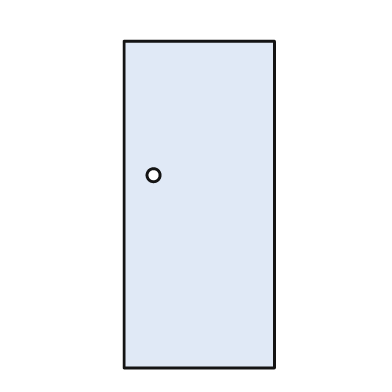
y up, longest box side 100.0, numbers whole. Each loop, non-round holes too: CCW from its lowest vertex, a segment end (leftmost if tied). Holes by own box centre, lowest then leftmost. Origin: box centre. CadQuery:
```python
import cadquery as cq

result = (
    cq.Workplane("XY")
    .moveTo(-23.0, -50.0)
    .lineTo(23.0, -50.0)
    .lineTo(23.0, 50.0)
    .lineTo(-23.0, 50.0)
    .close()
    .moveTo(-14.0, 9.0)
    .circle(2.0)
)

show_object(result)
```